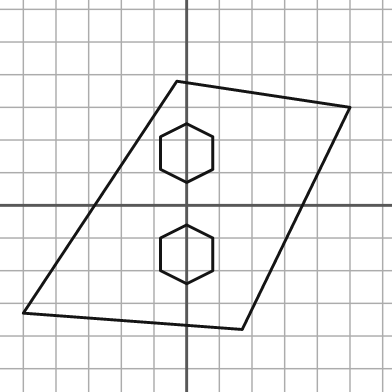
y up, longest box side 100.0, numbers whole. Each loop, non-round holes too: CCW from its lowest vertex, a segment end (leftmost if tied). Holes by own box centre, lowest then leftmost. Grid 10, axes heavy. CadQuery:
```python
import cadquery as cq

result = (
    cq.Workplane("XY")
    .moveTo(17.0, -38.0)
    .lineTo(50.0, 30.0)
    .lineTo(-3.0, 38.0)
    .lineTo(-50.0, -33.0)
    .close()
    .moveTo(0.0, -24.0)
    .lineTo(8.0, -20.0)
    .lineTo(8.0, -10.0)
    .lineTo(0.0, -6.0)
    .lineTo(-8.0, -10.0)
    .lineTo(-8.0, -20.0)
    .close()
    .moveTo(0.0, 7.0)
    .lineTo(8.0, 11.0)
    .lineTo(8.0, 21.0)
    .lineTo(0.0, 25.0)
    .lineTo(-8.0, 21.0)
    .lineTo(-8.0, 11.0)
    .close()
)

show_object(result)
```